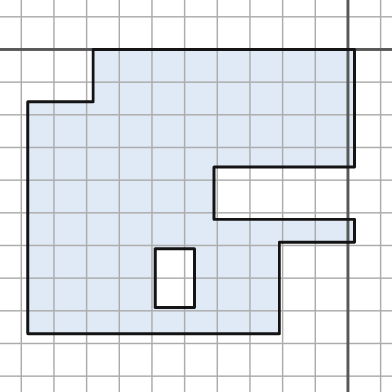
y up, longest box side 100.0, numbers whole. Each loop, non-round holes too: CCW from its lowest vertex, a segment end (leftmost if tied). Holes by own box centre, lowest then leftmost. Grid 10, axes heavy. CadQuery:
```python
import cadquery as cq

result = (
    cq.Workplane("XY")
    .moveTo(-98.0, -87.0)
    .lineTo(-21.0, -87.0)
    .lineTo(-21.0, -59.0)
    .lineTo(2.0, -59.0)
    .lineTo(2.0, -52.0)
    .lineTo(-41.0, -52.0)
    .lineTo(-41.0, -36.0)
    .lineTo(2.0, -36.0)
    .lineTo(2.0, 0.0)
    .lineTo(-78.0, 0.0)
    .lineTo(-78.0, -16.0)
    .lineTo(-98.0, -16.0)
    .close()
    .moveTo(-59.0, -79.0)
    .lineTo(-47.0, -79.0)
    .lineTo(-47.0, -61.0)
    .lineTo(-59.0, -61.0)
    .close()
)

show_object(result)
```